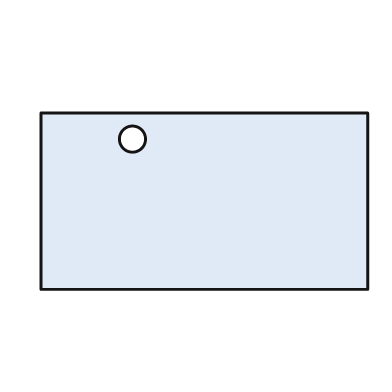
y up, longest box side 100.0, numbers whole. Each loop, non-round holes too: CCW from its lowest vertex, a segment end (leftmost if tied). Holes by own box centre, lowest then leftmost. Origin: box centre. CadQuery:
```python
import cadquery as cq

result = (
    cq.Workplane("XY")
    .moveTo(-50.0, -27.0)
    .lineTo(50.0, -27.0)
    .lineTo(50.0, 27.0)
    .lineTo(-50.0, 27.0)
    .close()
    .moveTo(-22.0, 19.0)
    .circle(4.0)
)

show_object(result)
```